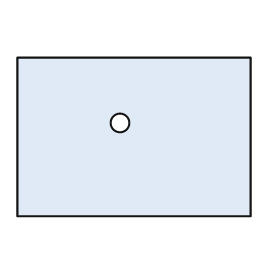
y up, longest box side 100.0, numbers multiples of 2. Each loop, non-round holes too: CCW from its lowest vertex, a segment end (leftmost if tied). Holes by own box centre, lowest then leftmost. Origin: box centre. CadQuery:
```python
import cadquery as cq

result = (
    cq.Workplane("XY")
    .moveTo(-50.0, -34.0)
    .lineTo(50.0, -34.0)
    .lineTo(50.0, 34.0)
    .lineTo(-50.0, 34.0)
    .close()
    .moveTo(-6.0, 6.0)
    .circle(4.0)
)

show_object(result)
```